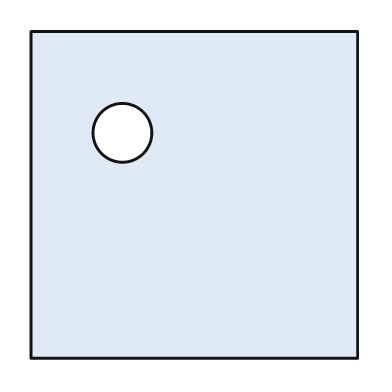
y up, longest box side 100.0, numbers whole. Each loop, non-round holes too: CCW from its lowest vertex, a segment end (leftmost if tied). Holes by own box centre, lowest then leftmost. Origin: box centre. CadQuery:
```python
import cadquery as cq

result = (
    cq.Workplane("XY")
    .moveTo(-50.0, -50.0)
    .lineTo(50.0, -50.0)
    .lineTo(50.0, 50.0)
    .lineTo(-50.0, 50.0)
    .close()
    .moveTo(-22.0, 19.0)
    .circle(9.0)
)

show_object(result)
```